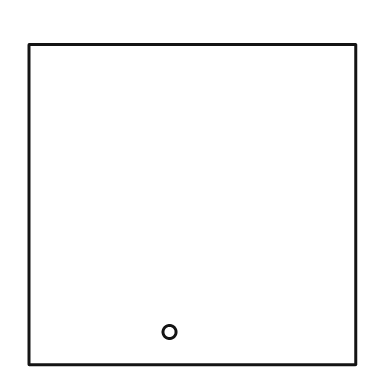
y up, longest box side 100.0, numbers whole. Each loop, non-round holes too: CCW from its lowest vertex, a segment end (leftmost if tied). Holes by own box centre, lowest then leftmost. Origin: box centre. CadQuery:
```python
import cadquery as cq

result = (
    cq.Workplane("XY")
    .moveTo(-50.0, -49.0)
    .lineTo(50.0, -49.0)
    .lineTo(50.0, 49.0)
    .lineTo(-50.0, 49.0)
    .close()
    .moveTo(-7.0, -39.0)
    .circle(2.0)
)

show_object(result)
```